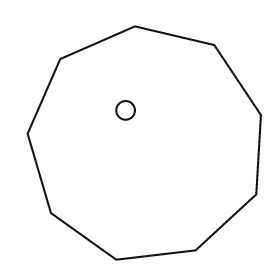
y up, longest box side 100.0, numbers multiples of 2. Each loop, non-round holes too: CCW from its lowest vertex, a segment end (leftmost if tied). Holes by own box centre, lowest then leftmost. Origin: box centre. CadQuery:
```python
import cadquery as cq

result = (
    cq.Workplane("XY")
    .moveTo(-12.0, -50.0)
    .lineTo(22.0, -46.0)
    .lineTo(48.0, -22.0)
    .lineTo(50.0, 12.0)
    .lineTo(30.0, 42.0)
    .lineTo(-4.0, 50.0)
    .lineTo(-36.0, 36.0)
    .lineTo(-50.0, 4.0)
    .lineTo(-40.0, -30.0)
    .close()
    .moveTo(-8.0, 14.0)
    .circle(4.0)
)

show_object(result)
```